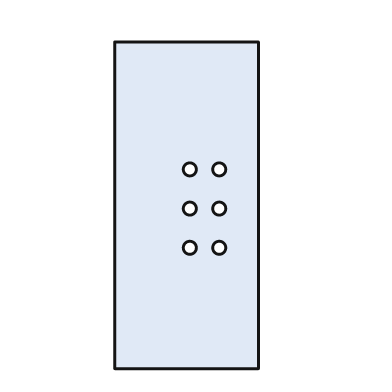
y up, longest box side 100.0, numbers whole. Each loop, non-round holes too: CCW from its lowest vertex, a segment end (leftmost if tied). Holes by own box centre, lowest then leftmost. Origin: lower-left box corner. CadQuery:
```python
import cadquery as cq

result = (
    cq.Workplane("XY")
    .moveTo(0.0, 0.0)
    .lineTo(44.0, 0.0)
    .lineTo(44.0, 100.0)
    .lineTo(0.0, 100.0)
    .close()
    .moveTo(23.0, 37.0)
    .circle(2.0)
    .moveTo(32.0, 37.0)
    .circle(2.0)
    .moveTo(23.0, 49.0)
    .circle(2.0)
    .moveTo(32.0, 49.0)
    .circle(2.0)
    .moveTo(23.0, 61.0)
    .circle(2.0)
    .moveTo(32.0, 61.0)
    .circle(2.0)
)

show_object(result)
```